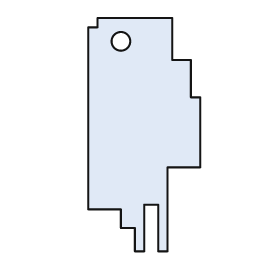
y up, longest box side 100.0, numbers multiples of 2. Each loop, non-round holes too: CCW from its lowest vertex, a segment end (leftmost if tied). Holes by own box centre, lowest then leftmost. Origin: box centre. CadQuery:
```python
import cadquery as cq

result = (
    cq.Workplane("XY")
    .moveTo(-4.0, -50.0)
    .lineTo(0.0, -50.0)
    .lineTo(0.0, -30.0)
    .lineTo(6.0, -30.0)
    .lineTo(6.0, -50.0)
    .lineTo(10.0, -50.0)
    .lineTo(10.0, -14.0)
    .lineTo(24.0, -14.0)
    .lineTo(24.0, 16.0)
    .lineTo(20.0, 16.0)
    .lineTo(20.0, 32.0)
    .lineTo(12.0, 32.0)
    .lineTo(12.0, 50.0)
    .lineTo(-20.0, 50.0)
    .lineTo(-20.0, 46.0)
    .lineTo(-24.0, 46.0)
    .lineTo(-24.0, -32.0)
    .lineTo(-10.0, -32.0)
    .lineTo(-10.0, -40.0)
    .lineTo(-4.0, -40.0)
    .close()
    .moveTo(-10.0, 40.0)
    .circle(4.0)
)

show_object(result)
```